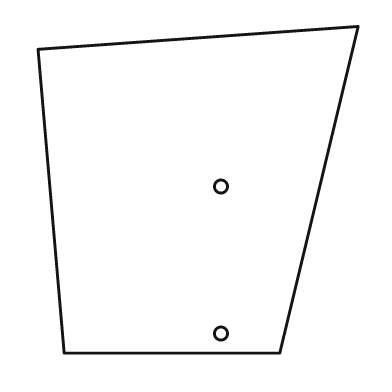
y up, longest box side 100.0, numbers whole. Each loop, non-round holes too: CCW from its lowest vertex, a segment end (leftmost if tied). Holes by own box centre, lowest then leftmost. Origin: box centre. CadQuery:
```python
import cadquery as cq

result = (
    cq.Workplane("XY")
    .moveTo(-41.0, -50.0)
    .lineTo(25.0, -50.0)
    .lineTo(49.0, 50.0)
    .lineTo(-49.0, 43.0)
    .close()
    .moveTo(7.0, -44.0)
    .circle(2.0)
    .moveTo(7.0, 1.0)
    .circle(2.0)
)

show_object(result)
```